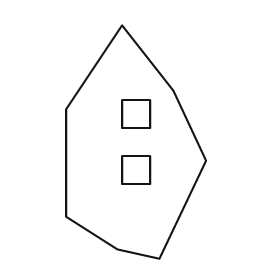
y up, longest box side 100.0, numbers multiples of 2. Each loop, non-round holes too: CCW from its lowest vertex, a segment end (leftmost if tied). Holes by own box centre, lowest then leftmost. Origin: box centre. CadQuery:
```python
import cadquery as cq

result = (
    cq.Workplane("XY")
    .moveTo(10.0, -50.0)
    .lineTo(30.0, -8.0)
    .lineTo(16.0, 22.0)
    .lineTo(-6.0, 50.0)
    .lineTo(-30.0, 14.0)
    .lineTo(-30.0, -32.0)
    .lineTo(-8.0, -46.0)
    .close()
    .moveTo(-6.0, -18.0)
    .lineTo(6.0, -18.0)
    .lineTo(6.0, -6.0)
    .lineTo(-6.0, -6.0)
    .close()
    .moveTo(-6.0, 6.0)
    .lineTo(6.0, 6.0)
    .lineTo(6.0, 18.0)
    .lineTo(-6.0, 18.0)
    .close()
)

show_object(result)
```